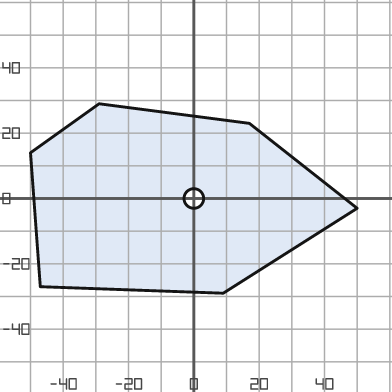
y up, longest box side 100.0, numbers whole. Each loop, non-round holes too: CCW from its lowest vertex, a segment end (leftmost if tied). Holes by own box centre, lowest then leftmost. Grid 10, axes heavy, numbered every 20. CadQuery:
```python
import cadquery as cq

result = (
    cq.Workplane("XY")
    .moveTo(9.0, -29.0)
    .lineTo(50.0, -3.0)
    .lineTo(17.0, 23.0)
    .lineTo(-29.0, 29.0)
    .lineTo(-50.0, 14.0)
    .lineTo(-47.0, -27.0)
    .close()
    .moveTo(0.0, 0.0)
    .circle(3.0)
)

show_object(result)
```